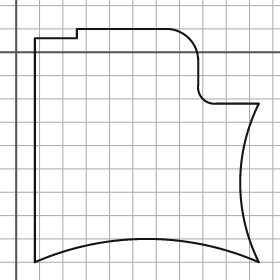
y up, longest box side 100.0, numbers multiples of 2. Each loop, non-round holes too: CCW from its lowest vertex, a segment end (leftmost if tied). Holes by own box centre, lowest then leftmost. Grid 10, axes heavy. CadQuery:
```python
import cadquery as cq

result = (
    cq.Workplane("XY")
    .moveTo(8.0, -90.0)
    .threePointArc((56.0, -80.0), (104.0, -90.0))
    .threePointArc((96.0, -56.0), (104.0, -22.0))
    .lineTo(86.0, -22.0)
    .threePointArc((80.0, -20.0), (78.0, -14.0))
    .lineTo(78.0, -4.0)
    .threePointArc((74.0, 6.0), (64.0, 10.0))
    .lineTo(26.0, 10.0)
    .lineTo(26.0, 6.0)
    .lineTo(8.0, 6.0)
    .close()
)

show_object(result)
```